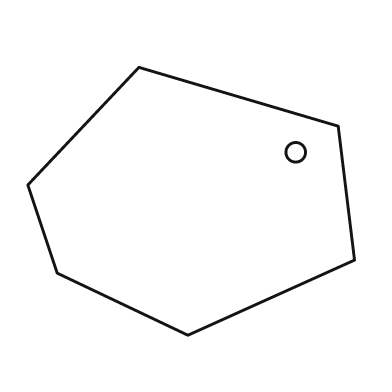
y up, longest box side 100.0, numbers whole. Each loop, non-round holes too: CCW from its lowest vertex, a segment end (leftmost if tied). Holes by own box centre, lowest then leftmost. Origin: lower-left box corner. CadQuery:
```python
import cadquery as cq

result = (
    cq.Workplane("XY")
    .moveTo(49.0, 0.0)
    .lineTo(100.0, 23.0)
    .lineTo(95.0, 64.0)
    .lineTo(34.0, 82.0)
    .lineTo(0.0, 46.0)
    .lineTo(9.0, 19.0)
    .close()
    .moveTo(82.0, 56.0)
    .circle(3.0)
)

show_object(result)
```